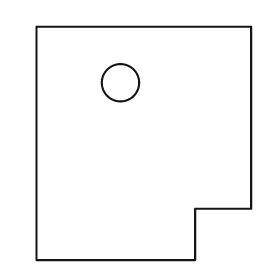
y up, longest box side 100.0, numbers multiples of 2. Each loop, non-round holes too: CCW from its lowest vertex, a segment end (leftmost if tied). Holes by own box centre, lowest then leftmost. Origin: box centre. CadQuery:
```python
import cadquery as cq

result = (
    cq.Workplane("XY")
    .moveTo(-46.0, -50.0)
    .lineTo(22.0, -50.0)
    .lineTo(22.0, -28.0)
    .lineTo(46.0, -28.0)
    .lineTo(46.0, 50.0)
    .lineTo(-46.0, 50.0)
    .close()
    .moveTo(-10.0, 26.0)
    .circle(8.0)
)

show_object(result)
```